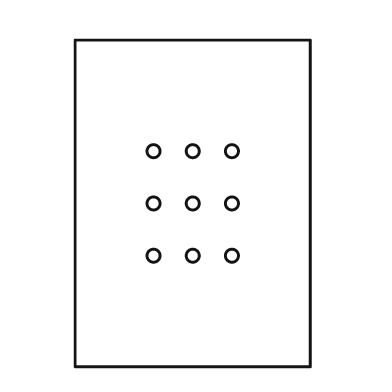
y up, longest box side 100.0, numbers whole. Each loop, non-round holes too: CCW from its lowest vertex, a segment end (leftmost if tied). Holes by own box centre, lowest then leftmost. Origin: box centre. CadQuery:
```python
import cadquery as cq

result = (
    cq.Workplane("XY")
    .moveTo(-36.0, -50.0)
    .lineTo(36.0, -50.0)
    .lineTo(36.0, 50.0)
    .lineTo(-36.0, 50.0)
    .close()
    .moveTo(-12.0, -16.0)
    .circle(2.0)
    .moveTo(0.0, -16.0)
    .circle(2.0)
    .moveTo(12.0, -16.0)
    .circle(2.0)
    .moveTo(-12.0, 0.0)
    .circle(2.0)
    .moveTo(0.0, 0.0)
    .circle(2.0)
    .moveTo(12.0, 0.0)
    .circle(2.0)
    .moveTo(-12.0, 16.0)
    .circle(2.0)
    .moveTo(0.0, 16.0)
    .circle(2.0)
    .moveTo(12.0, 16.0)
    .circle(2.0)
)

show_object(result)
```